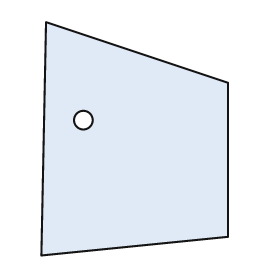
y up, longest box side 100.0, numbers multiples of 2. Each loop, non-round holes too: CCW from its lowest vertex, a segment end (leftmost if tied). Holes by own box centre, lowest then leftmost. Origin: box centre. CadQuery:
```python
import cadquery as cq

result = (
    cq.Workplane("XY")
    .moveTo(-40.0, -50.0)
    .lineTo(40.0, -42.0)
    .lineTo(40.0, 24.0)
    .lineTo(-38.0, 50.0)
    .close()
    .moveTo(-22.0, 8.0)
    .circle(4.0)
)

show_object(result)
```